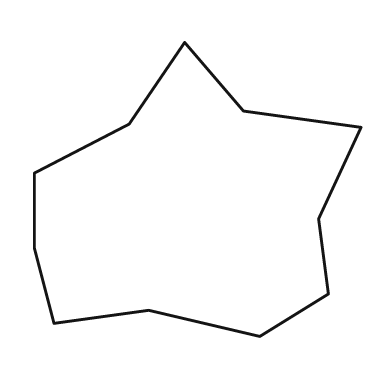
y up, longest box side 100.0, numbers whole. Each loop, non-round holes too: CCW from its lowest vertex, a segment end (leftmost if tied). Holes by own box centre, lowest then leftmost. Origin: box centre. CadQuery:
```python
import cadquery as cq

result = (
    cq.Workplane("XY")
    .moveTo(19.0, -45.0)
    .lineTo(40.0, -32.0)
    .lineTo(37.0, -9.0)
    .lineTo(50.0, 19.0)
    .lineTo(14.0, 24.0)
    .lineTo(-4.0, 45.0)
    .lineTo(-21.0, 20.0)
    .lineTo(-50.0, 5.0)
    .lineTo(-50.0, -18.0)
    .lineTo(-44.0, -41.0)
    .lineTo(-15.0, -37.0)
    .close()
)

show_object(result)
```